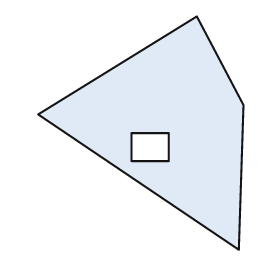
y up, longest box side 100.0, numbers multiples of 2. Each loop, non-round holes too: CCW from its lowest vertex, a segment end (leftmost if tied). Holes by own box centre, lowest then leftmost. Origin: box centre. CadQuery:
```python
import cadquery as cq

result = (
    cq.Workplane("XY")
    .moveTo(42.0, -50.0)
    .lineTo(44.0, 12.0)
    .lineTo(24.0, 50.0)
    .lineTo(-44.0, 8.0)
    .close()
    .moveTo(-4.0, -12.0)
    .lineTo(12.0, -12.0)
    .lineTo(12.0, 0.0)
    .lineTo(-4.0, 0.0)
    .close()
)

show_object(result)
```